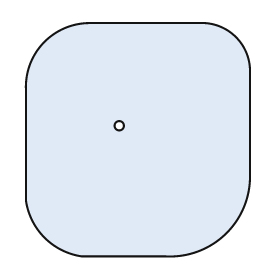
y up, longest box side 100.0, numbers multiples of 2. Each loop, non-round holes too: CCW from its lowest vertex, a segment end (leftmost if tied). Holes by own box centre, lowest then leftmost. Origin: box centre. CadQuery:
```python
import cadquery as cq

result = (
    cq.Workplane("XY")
    .moveTo(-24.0, -50.0)
    .lineTo(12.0, -50.0)
    .threePointArc((38.0, -40.0), (48.0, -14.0))
    .lineTo(48.0, 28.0)
    .threePointArc((42.0, 44.0), (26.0, 50.0))
    .lineTo(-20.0, 50.0)
    .threePointArc((-40.0, 42.0), (-48.0, 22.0))
    .lineTo(-48.0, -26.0)
    .threePointArc((-40.0, -42.0), (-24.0, -50.0))
    .close()
    .moveTo(-8.0, 6.0)
    .circle(2.0)
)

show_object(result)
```